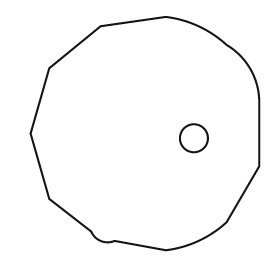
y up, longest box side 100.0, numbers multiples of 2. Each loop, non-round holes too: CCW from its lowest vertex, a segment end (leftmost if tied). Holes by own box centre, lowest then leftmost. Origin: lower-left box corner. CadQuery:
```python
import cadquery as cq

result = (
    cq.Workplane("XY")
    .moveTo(58.0, 0.0)
    .threePointArc((72.0, 4.0), (84.0, 12.0))
    .lineTo(98.0, 36.0)
    .lineTo(98.0, 64.0)
    .threePointArc((94.0, 78.0), (84.0, 88.0))
    .threePointArc((72.0, 96.0), (58.0, 100.0))
    .lineTo(30.0, 96.0)
    .lineTo(8.0, 78.0)
    .lineTo(0.0, 50.0)
    .lineTo(8.0, 22.0)
    .lineTo(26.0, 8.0)
    .threePointArc((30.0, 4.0), (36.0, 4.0))
    .close()
    .moveTo(70.0, 48.0)
    .circle(6.0)
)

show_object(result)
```